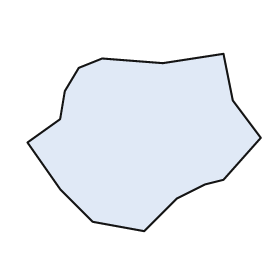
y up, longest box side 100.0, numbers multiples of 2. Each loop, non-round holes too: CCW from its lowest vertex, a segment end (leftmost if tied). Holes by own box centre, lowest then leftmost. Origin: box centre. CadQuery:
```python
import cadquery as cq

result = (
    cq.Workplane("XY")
    .moveTo(0.0, -38.0)
    .lineTo(14.0, -24.0)
    .lineTo(26.0, -18.0)
    .lineTo(34.0, -16.0)
    .lineTo(50.0, 2.0)
    .lineTo(38.0, 18.0)
    .lineTo(34.0, 38.0)
    .lineTo(8.0, 34.0)
    .lineTo(-18.0, 36.0)
    .lineTo(-28.0, 32.0)
    .lineTo(-34.0, 22.0)
    .lineTo(-36.0, 10.0)
    .lineTo(-50.0, 0.0)
    .lineTo(-36.0, -20.0)
    .lineTo(-22.0, -34.0)
    .close()
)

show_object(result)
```